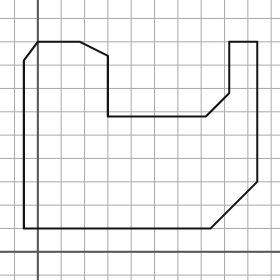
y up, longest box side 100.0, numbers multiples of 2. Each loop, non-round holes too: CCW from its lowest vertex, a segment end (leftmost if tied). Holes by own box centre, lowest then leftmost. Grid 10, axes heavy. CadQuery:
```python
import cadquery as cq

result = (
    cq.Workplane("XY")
    .moveTo(-6.0, 10.0)
    .lineTo(74.0, 10.0)
    .lineTo(94.0, 30.0)
    .lineTo(94.0, 90.0)
    .lineTo(82.0, 90.0)
    .lineTo(82.0, 68.0)
    .lineTo(72.0, 58.0)
    .lineTo(30.0, 58.0)
    .lineTo(30.0, 84.0)
    .lineTo(18.0, 90.0)
    .lineTo(0.0, 90.0)
    .lineTo(-6.0, 82.0)
    .close()
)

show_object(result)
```